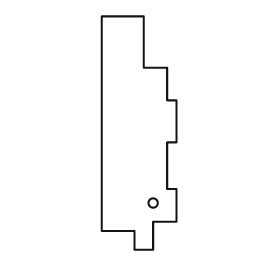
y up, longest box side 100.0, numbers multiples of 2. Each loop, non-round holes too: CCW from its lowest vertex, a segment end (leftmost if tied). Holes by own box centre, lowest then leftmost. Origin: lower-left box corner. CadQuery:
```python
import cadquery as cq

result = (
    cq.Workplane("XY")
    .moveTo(14.0, 0.0)
    .lineTo(22.0, 0.0)
    .lineTo(22.0, 12.0)
    .lineTo(32.0, 12.0)
    .lineTo(32.0, 26.0)
    .lineTo(28.0, 26.0)
    .lineTo(28.0, 46.0)
    .lineTo(32.0, 46.0)
    .lineTo(32.0, 64.0)
    .lineTo(28.0, 64.0)
    .lineTo(28.0, 78.0)
    .lineTo(18.0, 78.0)
    .lineTo(18.0, 100.0)
    .lineTo(0.0, 100.0)
    .lineTo(0.0, 8.0)
    .lineTo(14.0, 8.0)
    .close()
    .moveTo(22.0, 20.0)
    .circle(2.0)
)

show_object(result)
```